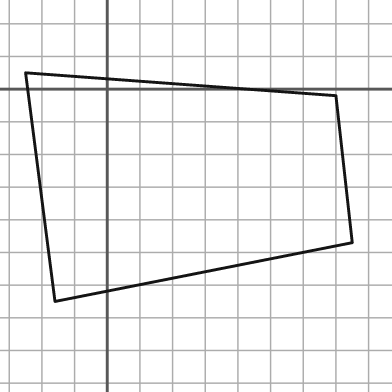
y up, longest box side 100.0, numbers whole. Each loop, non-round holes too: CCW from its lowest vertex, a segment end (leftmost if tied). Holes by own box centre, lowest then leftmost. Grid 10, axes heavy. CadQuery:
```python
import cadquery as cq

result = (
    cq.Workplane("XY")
    .moveTo(-16.0, -65.0)
    .lineTo(75.0, -47.0)
    .lineTo(70.0, -2.0)
    .lineTo(-25.0, 5.0)
    .close()
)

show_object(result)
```